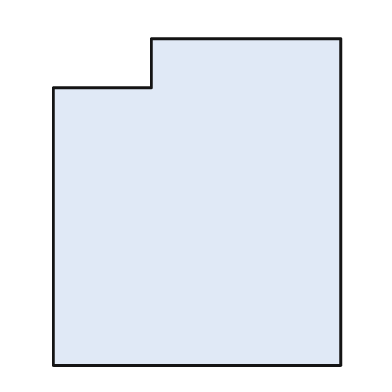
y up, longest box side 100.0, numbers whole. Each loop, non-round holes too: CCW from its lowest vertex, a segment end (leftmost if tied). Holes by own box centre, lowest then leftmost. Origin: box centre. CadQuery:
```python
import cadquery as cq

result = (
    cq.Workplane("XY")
    .moveTo(-44.0, -50.0)
    .lineTo(44.0, -50.0)
    .lineTo(44.0, 50.0)
    .lineTo(-14.0, 50.0)
    .lineTo(-14.0, 35.0)
    .lineTo(-44.0, 35.0)
    .close()
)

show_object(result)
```